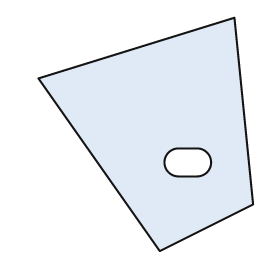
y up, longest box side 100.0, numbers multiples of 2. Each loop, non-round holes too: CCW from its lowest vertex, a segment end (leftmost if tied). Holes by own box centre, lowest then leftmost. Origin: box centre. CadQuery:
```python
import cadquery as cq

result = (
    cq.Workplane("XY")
    .moveTo(6.0, -50.0)
    .lineTo(46.0, -30.0)
    .lineTo(38.0, 50.0)
    .lineTo(-46.0, 24.0)
    .close()
    .moveTo(14.0, -18.0)
    .lineTo(22.0, -18.0)
    .threePointArc((28.0, -12.0), (22.0, -6.0))
    .lineTo(14.0, -6.0)
    .threePointArc((8.0, -12.0), (14.0, -18.0))
    .close()
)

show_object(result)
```